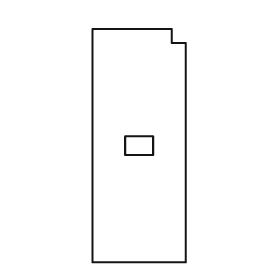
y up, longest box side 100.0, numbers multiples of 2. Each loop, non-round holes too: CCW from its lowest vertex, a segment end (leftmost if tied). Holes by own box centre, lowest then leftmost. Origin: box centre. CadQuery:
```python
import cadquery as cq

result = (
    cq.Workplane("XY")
    .moveTo(-20.0, -50.0)
    .lineTo(20.0, -50.0)
    .lineTo(20.0, 44.0)
    .lineTo(14.0, 44.0)
    .lineTo(14.0, 50.0)
    .lineTo(-20.0, 50.0)
    .close()
    .moveTo(-6.0, -4.0)
    .lineTo(6.0, -4.0)
    .lineTo(6.0, 4.0)
    .lineTo(-6.0, 4.0)
    .close()
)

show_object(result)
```